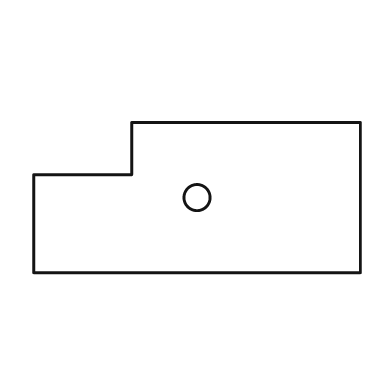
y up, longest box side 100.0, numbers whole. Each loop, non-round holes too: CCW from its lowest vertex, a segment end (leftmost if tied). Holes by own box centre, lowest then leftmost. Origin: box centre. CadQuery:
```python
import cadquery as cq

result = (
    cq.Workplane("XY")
    .moveTo(-50.0, -23.0)
    .lineTo(50.0, -23.0)
    .lineTo(50.0, 23.0)
    .lineTo(-20.0, 23.0)
    .lineTo(-20.0, 7.0)
    .lineTo(-50.0, 7.0)
    .close()
    .moveTo(0.0, 0.0)
    .circle(4.0)
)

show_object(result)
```